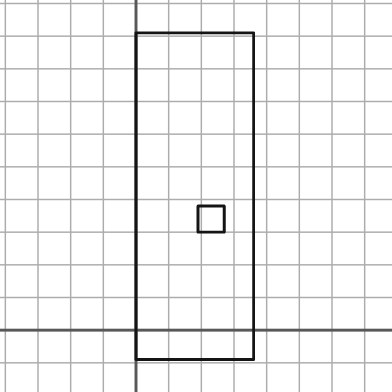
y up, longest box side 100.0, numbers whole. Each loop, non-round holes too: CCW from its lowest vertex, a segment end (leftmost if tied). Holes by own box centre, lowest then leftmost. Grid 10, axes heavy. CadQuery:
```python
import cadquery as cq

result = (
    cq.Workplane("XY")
    .moveTo(0.0, -9.0)
    .lineTo(36.0, -9.0)
    .lineTo(36.0, 91.0)
    .lineTo(0.0, 91.0)
    .close()
    .moveTo(19.0, 30.0)
    .lineTo(27.0, 30.0)
    .lineTo(27.0, 38.0)
    .lineTo(19.0, 38.0)
    .close()
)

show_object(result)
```